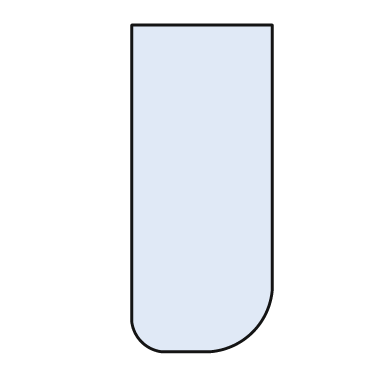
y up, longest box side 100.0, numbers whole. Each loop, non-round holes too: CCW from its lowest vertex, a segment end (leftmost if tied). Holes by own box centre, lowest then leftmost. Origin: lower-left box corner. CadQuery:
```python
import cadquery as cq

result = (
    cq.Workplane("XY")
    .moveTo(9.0, 0.0)
    .lineTo(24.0, 0.0)
    .threePointArc((37.0, 6.0), (43.0, 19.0))
    .lineTo(43.0, 100.0)
    .lineTo(0.0, 100.0)
    .lineTo(0.0, 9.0)
    .threePointArc((3.0, 3.0), (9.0, 0.0))
    .close()
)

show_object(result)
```